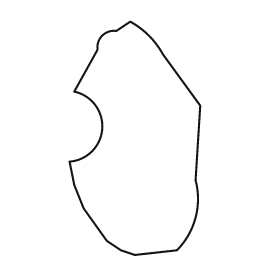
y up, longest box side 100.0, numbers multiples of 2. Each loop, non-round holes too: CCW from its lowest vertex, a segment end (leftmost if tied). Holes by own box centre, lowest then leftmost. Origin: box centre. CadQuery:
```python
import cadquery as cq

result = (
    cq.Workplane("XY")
    .moveTo(0.0, -50.0)
    .lineTo(18.0, -48.0)
    .threePointArc((26.0, -34.0), (26.0, -18.0))
    .lineTo(28.0, 14.0)
    .lineTo(12.0, 36.0)
    .threePointArc((6.0, 44.0), (-2.0, 50.0))
    .lineTo(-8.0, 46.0)
    .threePointArc((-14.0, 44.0), (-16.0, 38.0))
    .lineTo(-26.0, 20.0)
    .threePointArc((-14.0, 4.0), (-28.0, -10.0))
    .lineTo(-26.0, -20.0)
    .lineTo(-22.0, -30.0)
    .lineTo(-12.0, -44.0)
    .lineTo(-6.0, -48.0)
    .close()
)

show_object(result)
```